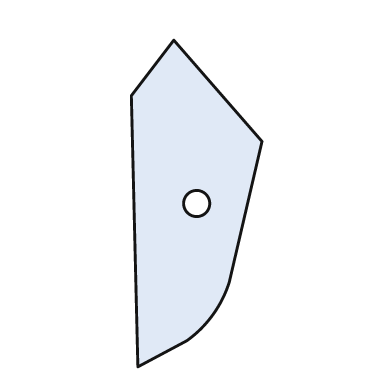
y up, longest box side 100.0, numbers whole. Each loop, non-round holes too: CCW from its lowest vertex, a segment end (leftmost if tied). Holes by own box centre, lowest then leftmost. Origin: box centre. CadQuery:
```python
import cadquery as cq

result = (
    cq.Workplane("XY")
    .moveTo(-18.0, -50.0)
    .lineTo(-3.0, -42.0)
    .threePointArc((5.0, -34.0), (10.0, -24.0))
    .lineTo(20.0, 19.0)
    .lineTo(-7.0, 50.0)
    .lineTo(-20.0, 33.0)
    .close()
    .moveTo(0.0, 0.0)
    .circle(4.0)
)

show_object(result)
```